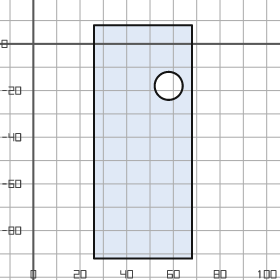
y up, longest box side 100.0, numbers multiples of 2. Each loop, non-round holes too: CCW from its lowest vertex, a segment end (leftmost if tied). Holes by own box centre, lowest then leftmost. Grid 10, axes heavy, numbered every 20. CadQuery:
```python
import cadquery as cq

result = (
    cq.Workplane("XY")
    .moveTo(26.0, -92.0)
    .lineTo(68.0, -92.0)
    .lineTo(68.0, 8.0)
    .lineTo(26.0, 8.0)
    .close()
    .moveTo(58.0, -18.0)
    .circle(6.0)
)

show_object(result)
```